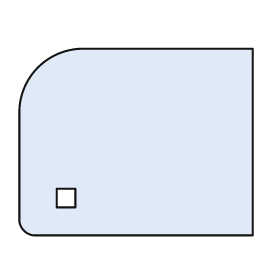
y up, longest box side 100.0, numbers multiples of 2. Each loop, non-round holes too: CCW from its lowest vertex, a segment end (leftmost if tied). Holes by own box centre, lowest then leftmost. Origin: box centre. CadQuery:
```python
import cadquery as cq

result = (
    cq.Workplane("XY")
    .moveTo(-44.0, -40.0)
    .lineTo(50.0, -40.0)
    .lineTo(50.0, 40.0)
    .lineTo(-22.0, 40.0)
    .threePointArc((-42.0, 32.0), (-50.0, 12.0))
    .lineTo(-50.0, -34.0)
    .threePointArc((-48.0, -38.0), (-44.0, -40.0))
    .close()
    .moveTo(-34.0, -28.0)
    .lineTo(-26.0, -28.0)
    .lineTo(-26.0, -20.0)
    .lineTo(-34.0, -20.0)
    .close()
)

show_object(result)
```